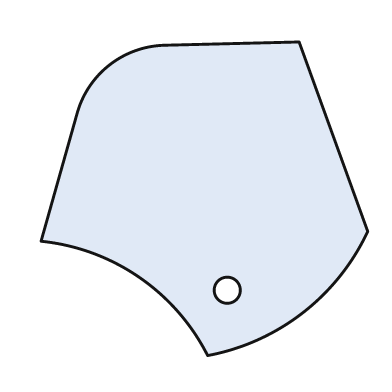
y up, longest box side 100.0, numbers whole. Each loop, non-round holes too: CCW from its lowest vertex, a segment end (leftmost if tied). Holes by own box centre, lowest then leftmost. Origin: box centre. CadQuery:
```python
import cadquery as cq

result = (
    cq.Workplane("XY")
    .moveTo(1.0, -48.0)
    .threePointArc((30.0, -35.0), (50.0, -10.0))
    .lineTo(29.0, 48.0)
    .lineTo(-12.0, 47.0)
    .threePointArc((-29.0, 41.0), (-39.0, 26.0))
    .lineTo(-50.0, -13.0)
    .threePointArc((-20.0, -24.0), (1.0, -48.0))
    .close()
    .moveTo(7.0, -28.0)
    .circle(4.0)
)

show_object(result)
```